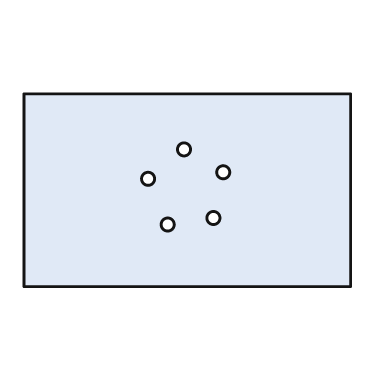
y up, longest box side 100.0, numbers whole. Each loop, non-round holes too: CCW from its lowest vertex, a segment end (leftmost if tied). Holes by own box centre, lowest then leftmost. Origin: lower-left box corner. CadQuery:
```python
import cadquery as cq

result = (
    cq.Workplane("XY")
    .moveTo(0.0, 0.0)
    .lineTo(100.0, 0.0)
    .lineTo(100.0, 59.0)
    .lineTo(0.0, 59.0)
    .close()
    .moveTo(44.0, 19.0)
    .circle(2.0)
    .moveTo(58.0, 21.0)
    .circle(2.0)
    .moveTo(38.0, 33.0)
    .circle(2.0)
    .moveTo(61.0, 35.0)
    .circle(2.0)
    .moveTo(49.0, 42.0)
    .circle(2.0)
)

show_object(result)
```